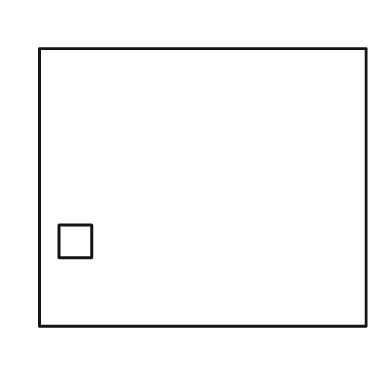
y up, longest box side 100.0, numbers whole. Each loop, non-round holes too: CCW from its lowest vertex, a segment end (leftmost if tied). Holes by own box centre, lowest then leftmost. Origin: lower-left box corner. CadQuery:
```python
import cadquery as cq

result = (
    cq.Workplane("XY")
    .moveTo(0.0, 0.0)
    .lineTo(100.0, 0.0)
    .lineTo(100.0, 85.0)
    .lineTo(0.0, 85.0)
    .close()
    .moveTo(6.0, 21.0)
    .lineTo(16.0, 21.0)
    .lineTo(16.0, 31.0)
    .lineTo(6.0, 31.0)
    .close()
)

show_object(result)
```